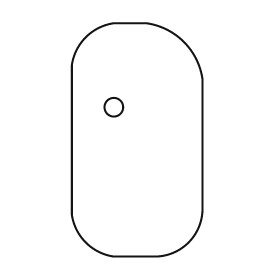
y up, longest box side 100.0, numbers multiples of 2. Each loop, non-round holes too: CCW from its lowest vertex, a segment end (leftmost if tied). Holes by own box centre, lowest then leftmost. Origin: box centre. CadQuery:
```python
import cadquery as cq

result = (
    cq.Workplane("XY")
    .moveTo(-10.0, -50.0)
    .lineTo(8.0, -50.0)
    .threePointArc((22.0, -44.0), (28.0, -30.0))
    .lineTo(28.0, 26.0)
    .threePointArc((20.0, 42.0), (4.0, 50.0))
    .lineTo(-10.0, 50.0)
    .threePointArc((-22.0, 44.0), (-28.0, 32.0))
    .lineTo(-28.0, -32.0)
    .threePointArc((-22.0, -44.0), (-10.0, -50.0))
    .close()
    .moveTo(-10.0, 14.0)
    .circle(4.0)
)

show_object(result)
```